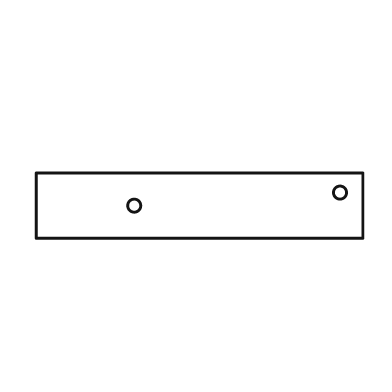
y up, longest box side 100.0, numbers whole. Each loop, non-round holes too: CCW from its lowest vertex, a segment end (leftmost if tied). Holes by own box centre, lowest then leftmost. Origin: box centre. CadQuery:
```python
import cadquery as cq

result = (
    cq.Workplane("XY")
    .moveTo(-50.0, -10.0)
    .lineTo(50.0, -10.0)
    .lineTo(50.0, 10.0)
    .lineTo(-50.0, 10.0)
    .close()
    .moveTo(-20.0, 0.0)
    .circle(2.0)
    .moveTo(43.0, 4.0)
    .circle(2.0)
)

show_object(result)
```